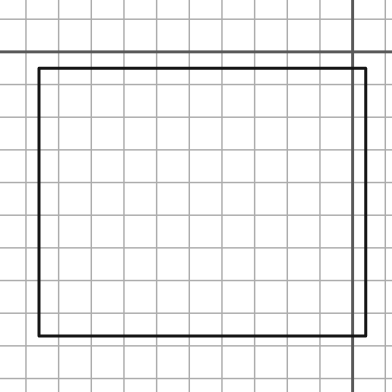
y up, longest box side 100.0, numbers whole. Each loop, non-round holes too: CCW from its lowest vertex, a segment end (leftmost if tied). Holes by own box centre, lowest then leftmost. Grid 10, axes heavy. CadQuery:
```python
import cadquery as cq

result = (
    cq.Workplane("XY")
    .moveTo(-96.0, -87.0)
    .lineTo(4.0, -87.0)
    .lineTo(4.0, -5.0)
    .lineTo(-96.0, -5.0)
    .close()
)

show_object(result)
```